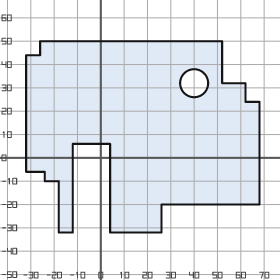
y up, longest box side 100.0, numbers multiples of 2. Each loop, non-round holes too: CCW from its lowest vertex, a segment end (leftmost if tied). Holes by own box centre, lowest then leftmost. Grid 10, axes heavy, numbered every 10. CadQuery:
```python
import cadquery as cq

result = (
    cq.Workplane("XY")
    .moveTo(-18.0, -32.0)
    .lineTo(-12.0, -32.0)
    .lineTo(-12.0, 6.0)
    .lineTo(4.0, 6.0)
    .lineTo(4.0, -32.0)
    .lineTo(26.0, -32.0)
    .lineTo(26.0, -20.0)
    .lineTo(68.0, -20.0)
    .lineTo(68.0, 24.0)
    .lineTo(62.0, 24.0)
    .lineTo(62.0, 32.0)
    .lineTo(52.0, 32.0)
    .lineTo(52.0, 50.0)
    .lineTo(-26.0, 50.0)
    .lineTo(-26.0, 44.0)
    .lineTo(-32.0, 44.0)
    .lineTo(-32.0, -6.0)
    .lineTo(-24.0, -6.0)
    .lineTo(-24.0, -10.0)
    .lineTo(-18.0, -10.0)
    .close()
    .moveTo(40.0, 32.0)
    .circle(6.0)
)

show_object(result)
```